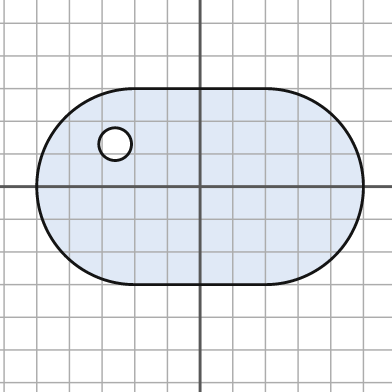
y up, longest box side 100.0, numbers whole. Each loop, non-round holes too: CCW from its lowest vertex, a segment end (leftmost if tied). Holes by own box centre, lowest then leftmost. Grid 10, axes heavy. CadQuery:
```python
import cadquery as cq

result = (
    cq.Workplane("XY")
    .moveTo(-20.0, -30.0)
    .lineTo(20.0, -30.0)
    .threePointArc((50.0, 0.0), (20.0, 30.0))
    .lineTo(-20.0, 30.0)
    .threePointArc((-50.0, 0.0), (-20.0, -30.0))
    .close()
    .moveTo(-26.0, 13.0)
    .circle(5.0)
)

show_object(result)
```